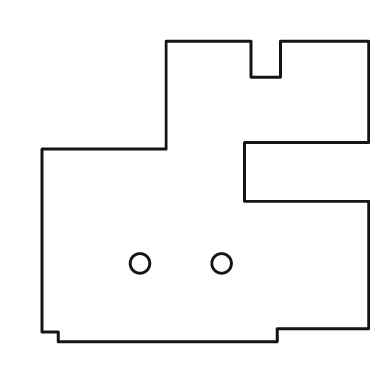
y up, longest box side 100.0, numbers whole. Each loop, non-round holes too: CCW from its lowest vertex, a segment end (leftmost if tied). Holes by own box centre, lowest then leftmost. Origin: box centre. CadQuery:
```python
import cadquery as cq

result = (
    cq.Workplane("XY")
    .moveTo(-45.0, -46.0)
    .lineTo(22.0, -46.0)
    .lineTo(22.0, -42.0)
    .lineTo(50.0, -42.0)
    .lineTo(50.0, -3.0)
    .lineTo(12.0, -3.0)
    .lineTo(12.0, 15.0)
    .lineTo(50.0, 15.0)
    .lineTo(50.0, 46.0)
    .lineTo(23.0, 46.0)
    .lineTo(23.0, 35.0)
    .lineTo(14.0, 35.0)
    .lineTo(14.0, 46.0)
    .lineTo(-12.0, 46.0)
    .lineTo(-12.0, 13.0)
    .lineTo(-50.0, 13.0)
    .lineTo(-50.0, -43.0)
    .lineTo(-45.0, -43.0)
    .close()
    .moveTo(-20.0, -22.0)
    .circle(3.0)
    .moveTo(5.0, -22.0)
    .circle(3.0)
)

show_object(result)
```